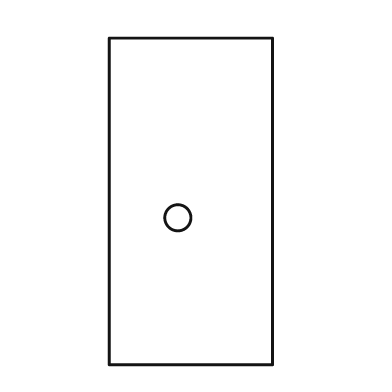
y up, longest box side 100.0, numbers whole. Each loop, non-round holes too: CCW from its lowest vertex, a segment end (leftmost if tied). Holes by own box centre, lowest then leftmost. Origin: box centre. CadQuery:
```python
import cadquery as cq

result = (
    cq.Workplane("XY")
    .moveTo(-25.0, -50.0)
    .lineTo(25.0, -50.0)
    .lineTo(25.0, 50.0)
    .lineTo(-25.0, 50.0)
    .close()
    .moveTo(-4.0, -5.0)
    .circle(4.0)
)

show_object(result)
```